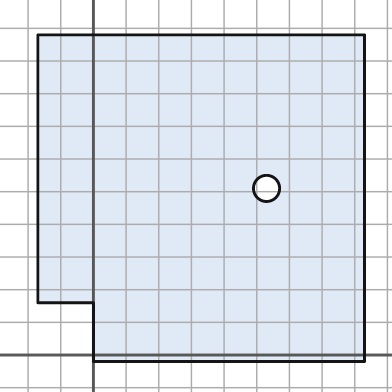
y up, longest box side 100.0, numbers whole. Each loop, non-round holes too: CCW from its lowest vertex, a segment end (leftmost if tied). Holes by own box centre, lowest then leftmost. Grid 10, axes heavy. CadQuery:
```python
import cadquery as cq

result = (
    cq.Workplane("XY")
    .moveTo(0.0, -2.0)
    .lineTo(83.0, -2.0)
    .lineTo(83.0, 98.0)
    .lineTo(-17.0, 98.0)
    .lineTo(-17.0, 16.0)
    .lineTo(0.0, 16.0)
    .close()
    .moveTo(53.0, 51.0)
    .circle(4.0)
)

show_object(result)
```